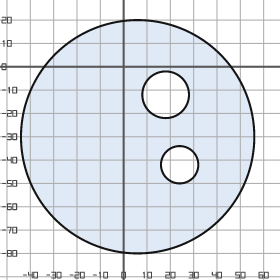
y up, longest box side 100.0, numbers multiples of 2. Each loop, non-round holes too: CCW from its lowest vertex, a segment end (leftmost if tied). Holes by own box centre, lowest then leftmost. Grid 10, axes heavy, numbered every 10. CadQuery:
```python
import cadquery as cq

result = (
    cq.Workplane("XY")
    .moveTo(6.0, -30.0)
    .circle(50.0)
    .moveTo(24.0, -42.0)
    .circle(8.0)
    .moveTo(18.0, -12.0)
    .circle(10.0)
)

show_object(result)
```